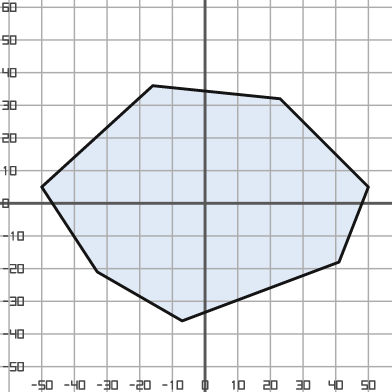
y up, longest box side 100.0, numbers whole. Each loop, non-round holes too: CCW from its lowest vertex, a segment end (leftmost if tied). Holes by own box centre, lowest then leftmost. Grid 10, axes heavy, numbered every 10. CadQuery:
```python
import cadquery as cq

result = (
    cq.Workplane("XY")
    .moveTo(-7.0, -36.0)
    .lineTo(41.0, -18.0)
    .lineTo(50.0, 5.0)
    .lineTo(23.0, 32.0)
    .lineTo(-16.0, 36.0)
    .lineTo(-50.0, 5.0)
    .lineTo(-33.0, -21.0)
    .close()
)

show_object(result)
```